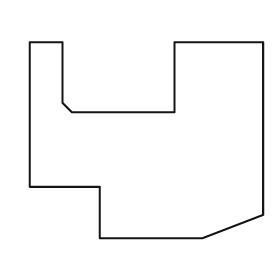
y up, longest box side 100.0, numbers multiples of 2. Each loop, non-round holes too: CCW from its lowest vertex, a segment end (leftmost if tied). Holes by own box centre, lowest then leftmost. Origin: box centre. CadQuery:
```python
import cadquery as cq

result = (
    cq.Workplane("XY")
    .moveTo(-20.0, -42.0)
    .lineTo(24.0, -42.0)
    .lineTo(50.0, -32.0)
    .lineTo(50.0, 42.0)
    .lineTo(12.0, 42.0)
    .lineTo(12.0, 12.0)
    .lineTo(-32.0, 12.0)
    .lineTo(-36.0, 16.0)
    .lineTo(-36.0, 42.0)
    .lineTo(-50.0, 42.0)
    .lineTo(-50.0, -20.0)
    .lineTo(-20.0, -20.0)
    .close()
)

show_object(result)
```